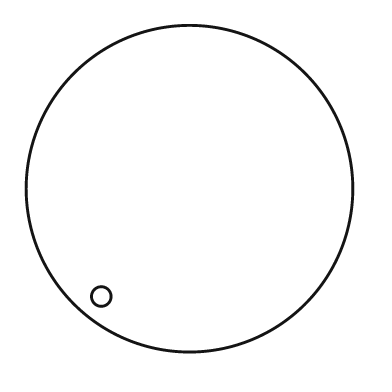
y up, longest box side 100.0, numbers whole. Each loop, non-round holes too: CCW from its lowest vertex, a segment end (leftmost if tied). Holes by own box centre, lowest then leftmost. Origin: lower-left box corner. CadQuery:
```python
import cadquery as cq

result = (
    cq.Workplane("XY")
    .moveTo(50.0, 50.0)
    .circle(50.0)
    .moveTo(23.0, 17.0)
    .circle(3.0)
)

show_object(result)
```